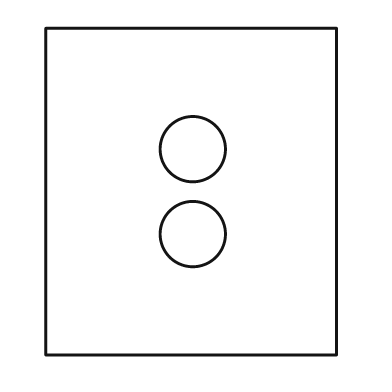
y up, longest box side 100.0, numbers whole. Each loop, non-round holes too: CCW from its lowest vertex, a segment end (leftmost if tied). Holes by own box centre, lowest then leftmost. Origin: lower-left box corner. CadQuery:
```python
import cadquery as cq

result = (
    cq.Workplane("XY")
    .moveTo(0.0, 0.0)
    .lineTo(89.0, 0.0)
    .lineTo(89.0, 100.0)
    .lineTo(0.0, 100.0)
    .close()
    .moveTo(45.0, 37.0)
    .circle(10.0)
    .moveTo(45.0, 63.0)
    .circle(10.0)
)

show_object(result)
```